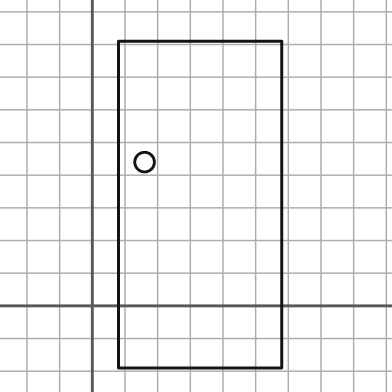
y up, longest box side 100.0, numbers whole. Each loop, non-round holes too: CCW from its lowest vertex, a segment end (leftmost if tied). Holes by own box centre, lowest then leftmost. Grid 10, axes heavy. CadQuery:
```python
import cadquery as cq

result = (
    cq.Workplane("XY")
    .moveTo(8.0, -19.0)
    .lineTo(58.0, -19.0)
    .lineTo(58.0, 81.0)
    .lineTo(8.0, 81.0)
    .close()
    .moveTo(16.0, 44.0)
    .circle(3.0)
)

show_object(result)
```